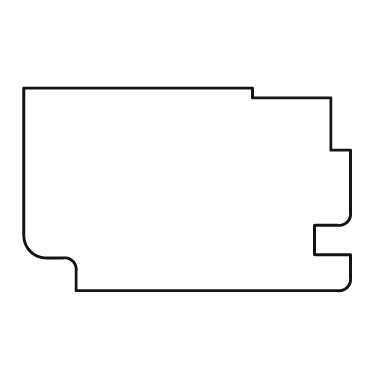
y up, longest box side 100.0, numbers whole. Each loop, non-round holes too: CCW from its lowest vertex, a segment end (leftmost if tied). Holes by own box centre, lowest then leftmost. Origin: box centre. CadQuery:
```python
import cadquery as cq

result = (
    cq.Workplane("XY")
    .moveTo(-34.0, -31.0)
    .lineTo(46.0, -31.0)
    .threePointArc((49.0, -30.0), (50.0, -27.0))
    .lineTo(50.0, -20.0)
    .lineTo(39.0, -20.0)
    .lineTo(39.0, -11.0)
    .lineTo(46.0, -11.0)
    .threePointArc((49.0, -10.0), (50.0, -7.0))
    .lineTo(50.0, 12.0)
    .lineTo(44.0, 12.0)
    .lineTo(44.0, 28.0)
    .lineTo(20.0, 28.0)
    .lineTo(20.0, 31.0)
    .lineTo(-50.0, 31.0)
    .lineTo(-50.0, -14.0)
    .threePointArc((-48.0, -19.0), (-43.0, -21.0))
    .lineTo(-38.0, -21.0)
    .threePointArc((-35.0, -22.0), (-34.0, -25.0))
    .close()
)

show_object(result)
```